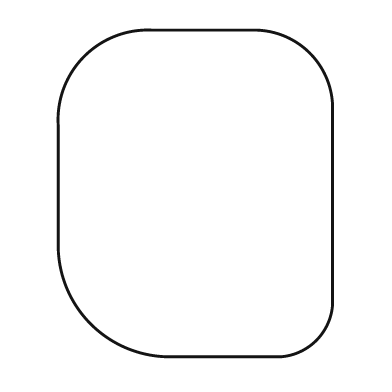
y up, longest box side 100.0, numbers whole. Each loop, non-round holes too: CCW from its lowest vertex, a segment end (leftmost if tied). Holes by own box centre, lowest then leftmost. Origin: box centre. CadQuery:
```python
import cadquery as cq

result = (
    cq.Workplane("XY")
    .moveTo(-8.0, -50.0)
    .lineTo(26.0, -50.0)
    .threePointArc((37.0, -45.0), (42.0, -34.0))
    .lineTo(42.0, 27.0)
    .threePointArc((35.0, 43.0), (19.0, 50.0))
    .lineTo(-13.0, 50.0)
    .threePointArc((-34.0, 42.0), (-42.0, 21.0))
    .lineTo(-42.0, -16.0)
    .threePointArc((-32.0, -40.0), (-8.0, -50.0))
    .close()
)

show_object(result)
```